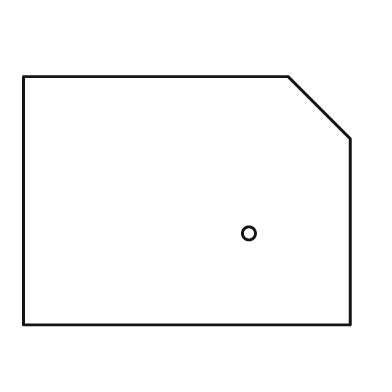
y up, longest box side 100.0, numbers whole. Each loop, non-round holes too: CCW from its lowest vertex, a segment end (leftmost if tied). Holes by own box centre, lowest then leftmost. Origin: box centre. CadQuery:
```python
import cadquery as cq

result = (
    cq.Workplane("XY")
    .moveTo(-50.0, -38.0)
    .lineTo(50.0, -38.0)
    .lineTo(50.0, 19.0)
    .lineTo(31.0, 38.0)
    .lineTo(-50.0, 38.0)
    .close()
    .moveTo(19.0, -10.0)
    .circle(2.0)
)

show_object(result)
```